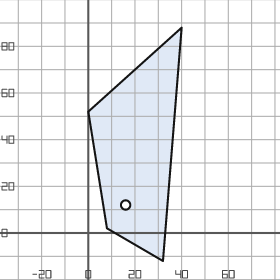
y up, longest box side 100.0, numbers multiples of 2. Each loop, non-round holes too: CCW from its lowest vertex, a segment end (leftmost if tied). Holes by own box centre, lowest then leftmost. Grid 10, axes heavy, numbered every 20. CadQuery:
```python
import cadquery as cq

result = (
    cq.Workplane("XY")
    .moveTo(32.0, -12.0)
    .lineTo(40.0, 88.0)
    .lineTo(0.0, 52.0)
    .lineTo(8.0, 2.0)
    .close()
    .moveTo(16.0, 12.0)
    .circle(2.0)
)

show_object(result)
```